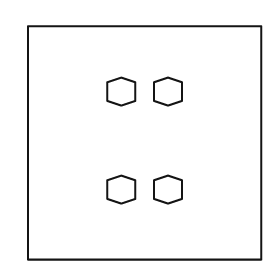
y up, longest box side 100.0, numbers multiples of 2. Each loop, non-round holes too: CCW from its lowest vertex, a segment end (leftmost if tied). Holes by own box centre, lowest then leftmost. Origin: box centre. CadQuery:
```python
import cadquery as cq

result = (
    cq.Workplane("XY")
    .moveTo(-50.0, -50.0)
    .lineTo(50.0, -50.0)
    .lineTo(50.0, 50.0)
    .lineTo(-50.0, 50.0)
    .close()
    .moveTo(-10.0, -26.0)
    .lineTo(-4.0, -24.0)
    .lineTo(-4.0, -16.0)
    .lineTo(-10.0, -14.0)
    .lineTo(-16.0, -16.0)
    .lineTo(-16.0, -24.0)
    .close()
    .moveTo(10.0, -26.0)
    .lineTo(16.0, -24.0)
    .lineTo(16.0, -16.0)
    .lineTo(10.0, -14.0)
    .lineTo(4.0, -16.0)
    .lineTo(4.0, -24.0)
    .close()
    .moveTo(-10.0, 16.0)
    .lineTo(-4.0, 18.0)
    .lineTo(-4.0, 26.0)
    .lineTo(-10.0, 28.0)
    .lineTo(-16.0, 26.0)
    .lineTo(-16.0, 18.0)
    .close()
    .moveTo(10.0, 16.0)
    .lineTo(16.0, 18.0)
    .lineTo(16.0, 26.0)
    .lineTo(10.0, 28.0)
    .lineTo(4.0, 26.0)
    .lineTo(4.0, 18.0)
    .close()
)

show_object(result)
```